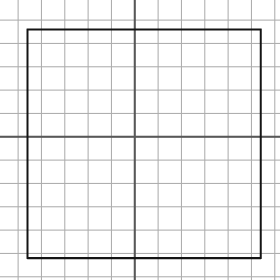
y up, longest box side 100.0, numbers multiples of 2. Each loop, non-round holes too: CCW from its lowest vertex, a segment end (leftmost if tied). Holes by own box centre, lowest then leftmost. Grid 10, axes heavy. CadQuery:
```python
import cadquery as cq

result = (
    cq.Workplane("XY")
    .moveTo(-46.0, -52.0)
    .lineTo(54.0, -52.0)
    .lineTo(54.0, 46.0)
    .lineTo(-46.0, 46.0)
    .close()
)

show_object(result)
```